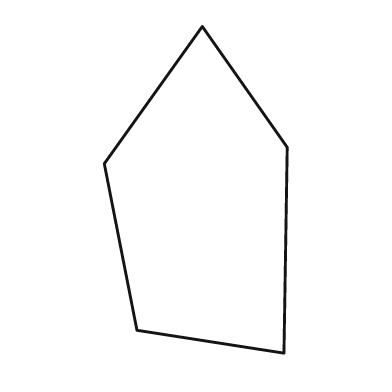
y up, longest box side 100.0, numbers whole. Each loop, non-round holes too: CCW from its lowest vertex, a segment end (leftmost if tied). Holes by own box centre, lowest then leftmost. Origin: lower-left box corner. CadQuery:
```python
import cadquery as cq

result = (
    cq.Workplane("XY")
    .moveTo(55.0, 0.0)
    .lineTo(56.0, 63.0)
    .lineTo(30.0, 100.0)
    .lineTo(0.0, 58.0)
    .lineTo(10.0, 7.0)
    .close()
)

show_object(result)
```